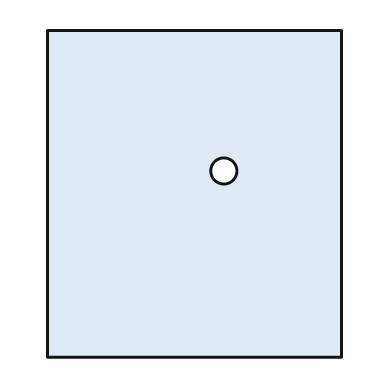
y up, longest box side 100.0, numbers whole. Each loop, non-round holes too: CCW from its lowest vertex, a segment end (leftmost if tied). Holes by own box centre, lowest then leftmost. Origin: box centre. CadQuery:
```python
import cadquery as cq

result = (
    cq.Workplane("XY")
    .moveTo(-45.0, -50.0)
    .lineTo(45.0, -50.0)
    .lineTo(45.0, 50.0)
    .lineTo(-45.0, 50.0)
    .close()
    .moveTo(9.0, 7.0)
    .circle(4.0)
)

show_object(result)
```